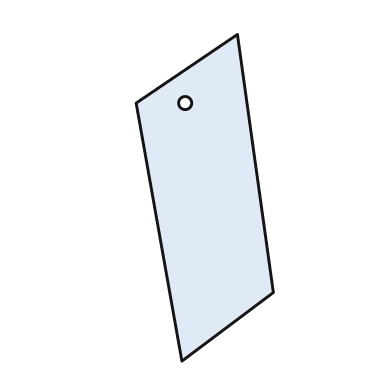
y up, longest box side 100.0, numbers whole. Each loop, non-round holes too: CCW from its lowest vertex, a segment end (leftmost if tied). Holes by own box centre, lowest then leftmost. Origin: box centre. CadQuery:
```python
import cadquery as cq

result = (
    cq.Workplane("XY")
    .moveTo(-7.0, -50.0)
    .lineTo(21.0, -29.0)
    .lineTo(10.0, 50.0)
    .lineTo(-21.0, 29.0)
    .close()
    .moveTo(-6.0, 29.0)
    .circle(2.0)
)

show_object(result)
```